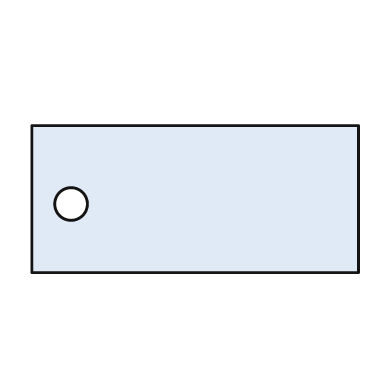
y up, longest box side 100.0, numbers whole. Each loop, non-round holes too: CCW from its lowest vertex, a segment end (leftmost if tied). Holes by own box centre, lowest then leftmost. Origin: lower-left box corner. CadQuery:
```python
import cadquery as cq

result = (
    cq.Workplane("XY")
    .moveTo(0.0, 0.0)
    .lineTo(100.0, 0.0)
    .lineTo(100.0, 45.0)
    .lineTo(0.0, 45.0)
    .close()
    .moveTo(12.0, 21.0)
    .circle(5.0)
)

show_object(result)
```